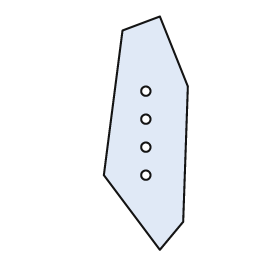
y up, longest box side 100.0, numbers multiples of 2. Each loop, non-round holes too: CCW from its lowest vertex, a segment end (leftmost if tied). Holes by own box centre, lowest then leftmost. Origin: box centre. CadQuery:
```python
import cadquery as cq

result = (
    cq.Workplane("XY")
    .moveTo(6.0, -50.0)
    .lineTo(16.0, -38.0)
    .lineTo(18.0, 20.0)
    .lineTo(6.0, 50.0)
    .lineTo(-10.0, 44.0)
    .lineTo(-18.0, -18.0)
    .close()
    .moveTo(0.0, -18.0)
    .circle(2.0)
    .moveTo(0.0, -6.0)
    .circle(2.0)
    .moveTo(0.0, 6.0)
    .circle(2.0)
    .moveTo(0.0, 18.0)
    .circle(2.0)
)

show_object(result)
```